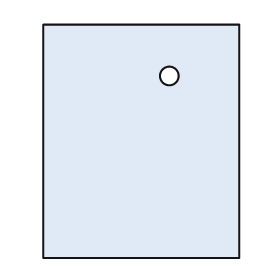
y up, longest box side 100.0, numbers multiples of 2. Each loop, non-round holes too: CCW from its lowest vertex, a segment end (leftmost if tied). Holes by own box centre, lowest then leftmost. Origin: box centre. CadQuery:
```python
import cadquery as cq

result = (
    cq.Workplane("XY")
    .moveTo(-42.0, -50.0)
    .lineTo(42.0, -50.0)
    .lineTo(42.0, 50.0)
    .lineTo(-42.0, 50.0)
    .close()
    .moveTo(12.0, 28.0)
    .circle(4.0)
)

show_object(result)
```